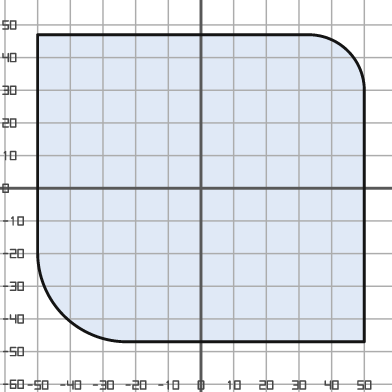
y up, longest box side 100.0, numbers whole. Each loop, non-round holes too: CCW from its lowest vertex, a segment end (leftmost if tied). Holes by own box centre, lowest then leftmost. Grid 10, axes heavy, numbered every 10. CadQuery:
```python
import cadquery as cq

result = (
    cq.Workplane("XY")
    .moveTo(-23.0, -47.0)
    .lineTo(50.0, -47.0)
    .lineTo(50.0, 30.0)
    .threePointArc((45.0, 42.0), (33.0, 47.0))
    .lineTo(-50.0, 47.0)
    .lineTo(-50.0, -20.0)
    .threePointArc((-42.0, -39.0), (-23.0, -47.0))
    .close()
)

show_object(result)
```